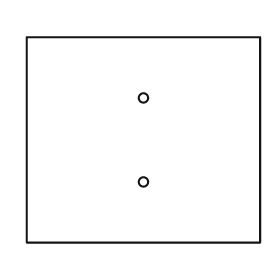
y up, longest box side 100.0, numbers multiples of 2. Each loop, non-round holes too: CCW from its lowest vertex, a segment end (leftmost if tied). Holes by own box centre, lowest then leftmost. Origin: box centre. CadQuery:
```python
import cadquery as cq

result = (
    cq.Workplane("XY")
    .moveTo(-50.0, -44.0)
    .lineTo(50.0, -44.0)
    .lineTo(50.0, 44.0)
    .lineTo(-50.0, 44.0)
    .close()
    .moveTo(0.0, -18.0)
    .circle(2.0)
    .moveTo(0.0, 18.0)
    .circle(2.0)
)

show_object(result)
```